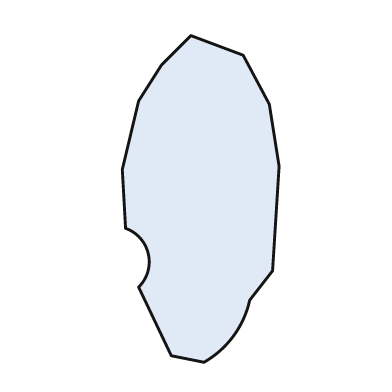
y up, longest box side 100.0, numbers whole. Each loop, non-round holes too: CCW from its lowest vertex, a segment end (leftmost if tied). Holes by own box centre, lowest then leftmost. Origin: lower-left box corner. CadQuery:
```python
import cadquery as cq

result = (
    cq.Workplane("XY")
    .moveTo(25.0, 0.0)
    .threePointArc((34.0, 8.0), (39.0, 19.0))
    .lineTo(46.0, 28.0)
    .lineTo(48.0, 60.0)
    .lineTo(45.0, 79.0)
    .lineTo(37.0, 94.0)
    .lineTo(21.0, 100.0)
    .lineTo(12.0, 91.0)
    .lineTo(5.0, 80.0)
    .lineTo(0.0, 59.0)
    .lineTo(1.0, 41.0)
    .threePointArc((8.0, 33.0), (5.0, 23.0))
    .lineTo(15.0, 2.0)
    .close()
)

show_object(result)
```